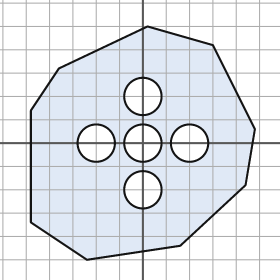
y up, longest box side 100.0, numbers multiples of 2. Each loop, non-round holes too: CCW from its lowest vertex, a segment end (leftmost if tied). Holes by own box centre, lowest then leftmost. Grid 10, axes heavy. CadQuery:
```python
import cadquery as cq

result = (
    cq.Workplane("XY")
    .moveTo(-24.0, -50.0)
    .lineTo(16.0, -44.0)
    .lineTo(44.0, -18.0)
    .lineTo(48.0, 6.0)
    .lineTo(30.0, 42.0)
    .lineTo(2.0, 50.0)
    .lineTo(-36.0, 32.0)
    .lineTo(-48.0, 14.0)
    .lineTo(-48.0, -34.0)
    .close()
    .moveTo(0.0, -20.0)
    .circle(8.0)
    .moveTo(-20.0, 0.0)
    .circle(8.0)
    .moveTo(0.0, 0.0)
    .circle(8.0)
    .moveTo(20.0, 0.0)
    .circle(8.0)
    .moveTo(0.0, 20.0)
    .circle(8.0)
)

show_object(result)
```